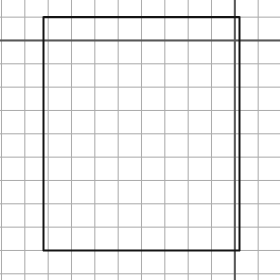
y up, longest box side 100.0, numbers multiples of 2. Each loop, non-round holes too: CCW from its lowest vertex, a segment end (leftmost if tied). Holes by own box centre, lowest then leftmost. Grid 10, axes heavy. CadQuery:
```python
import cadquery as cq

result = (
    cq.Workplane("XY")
    .moveTo(-82.0, -90.0)
    .lineTo(2.0, -90.0)
    .lineTo(2.0, 10.0)
    .lineTo(-82.0, 10.0)
    .close()
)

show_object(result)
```